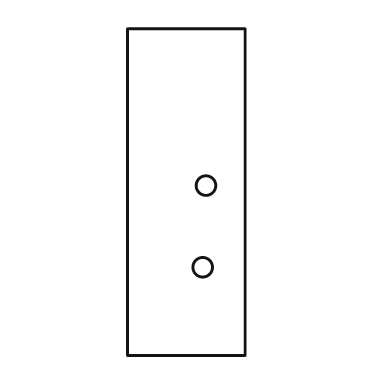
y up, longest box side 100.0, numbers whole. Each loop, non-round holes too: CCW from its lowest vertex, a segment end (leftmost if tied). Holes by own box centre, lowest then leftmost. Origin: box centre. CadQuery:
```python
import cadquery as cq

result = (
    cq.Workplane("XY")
    .moveTo(-18.0, -50.0)
    .lineTo(18.0, -50.0)
    .lineTo(18.0, 50.0)
    .lineTo(-18.0, 50.0)
    .close()
    .moveTo(5.0, -23.0)
    .circle(3.0)
    .moveTo(6.0, 2.0)
    .circle(3.0)
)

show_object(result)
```